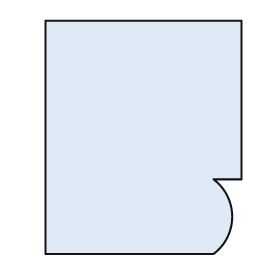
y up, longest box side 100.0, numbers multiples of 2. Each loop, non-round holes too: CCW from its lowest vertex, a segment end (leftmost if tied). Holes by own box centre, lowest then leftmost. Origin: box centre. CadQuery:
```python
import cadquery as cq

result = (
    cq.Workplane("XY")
    .moveTo(-42.0, -50.0)
    .lineTo(30.0, -50.0)
    .threePointArc((38.0, -34.0), (30.0, -18.0))
    .lineTo(42.0, -18.0)
    .lineTo(42.0, 50.0)
    .lineTo(-42.0, 50.0)
    .close()
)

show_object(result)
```